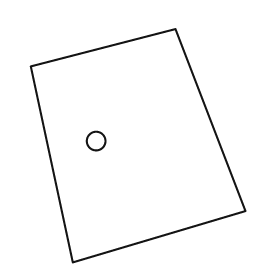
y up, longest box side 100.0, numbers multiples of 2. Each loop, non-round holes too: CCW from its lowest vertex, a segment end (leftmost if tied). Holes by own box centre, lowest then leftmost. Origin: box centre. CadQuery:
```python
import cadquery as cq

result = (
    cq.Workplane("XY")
    .moveTo(-28.0, -50.0)
    .lineTo(46.0, -28.0)
    .lineTo(16.0, 50.0)
    .lineTo(-46.0, 34.0)
    .close()
    .moveTo(-18.0, 2.0)
    .circle(4.0)
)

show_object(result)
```